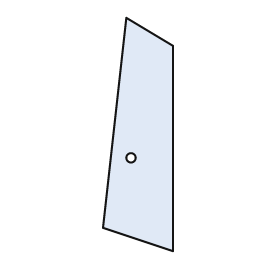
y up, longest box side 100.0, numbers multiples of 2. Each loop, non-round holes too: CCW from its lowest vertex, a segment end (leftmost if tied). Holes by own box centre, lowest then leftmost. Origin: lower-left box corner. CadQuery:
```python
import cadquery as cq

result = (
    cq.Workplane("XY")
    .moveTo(30.0, 0.0)
    .lineTo(30.0, 88.0)
    .lineTo(10.0, 100.0)
    .lineTo(0.0, 10.0)
    .close()
    .moveTo(12.0, 40.0)
    .circle(2.0)
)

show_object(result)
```